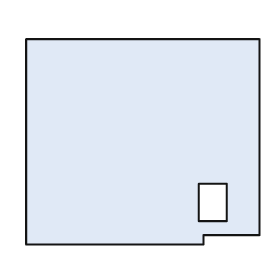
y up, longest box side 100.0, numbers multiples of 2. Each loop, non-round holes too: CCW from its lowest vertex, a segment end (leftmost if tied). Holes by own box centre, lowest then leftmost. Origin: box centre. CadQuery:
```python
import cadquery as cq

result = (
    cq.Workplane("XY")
    .moveTo(-50.0, -44.0)
    .lineTo(26.0, -44.0)
    .lineTo(26.0, -40.0)
    .lineTo(50.0, -40.0)
    .lineTo(50.0, 44.0)
    .lineTo(-50.0, 44.0)
    .close()
    .moveTo(24.0, -34.0)
    .lineTo(36.0, -34.0)
    .lineTo(36.0, -18.0)
    .lineTo(24.0, -18.0)
    .close()
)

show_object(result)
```